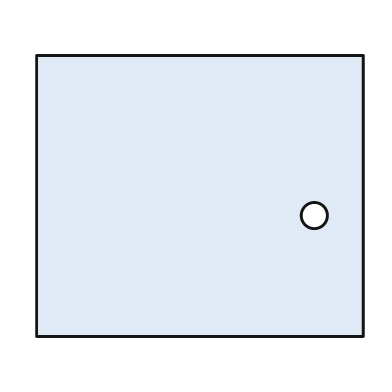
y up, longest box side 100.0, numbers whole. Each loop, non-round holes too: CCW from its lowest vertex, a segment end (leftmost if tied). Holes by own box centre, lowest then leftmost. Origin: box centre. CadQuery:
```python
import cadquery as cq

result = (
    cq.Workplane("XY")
    .moveTo(-50.0, -43.0)
    .lineTo(50.0, -43.0)
    .lineTo(50.0, 43.0)
    .lineTo(-50.0, 43.0)
    .close()
    .moveTo(35.0, -6.0)
    .circle(4.0)
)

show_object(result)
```